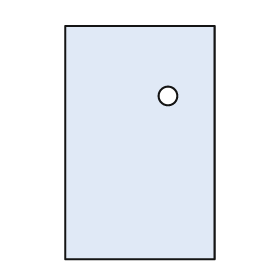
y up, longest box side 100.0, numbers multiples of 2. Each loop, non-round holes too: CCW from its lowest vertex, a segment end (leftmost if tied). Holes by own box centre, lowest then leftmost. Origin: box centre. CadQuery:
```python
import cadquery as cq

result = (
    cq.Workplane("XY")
    .moveTo(-32.0, -50.0)
    .lineTo(32.0, -50.0)
    .lineTo(32.0, 50.0)
    .lineTo(-32.0, 50.0)
    .close()
    .moveTo(12.0, 20.0)
    .circle(4.0)
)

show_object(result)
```